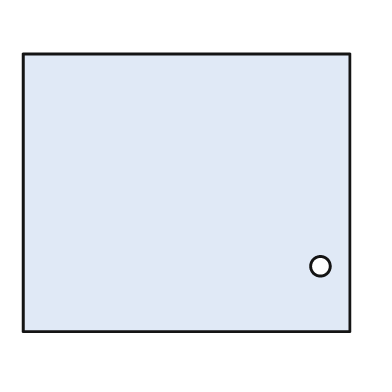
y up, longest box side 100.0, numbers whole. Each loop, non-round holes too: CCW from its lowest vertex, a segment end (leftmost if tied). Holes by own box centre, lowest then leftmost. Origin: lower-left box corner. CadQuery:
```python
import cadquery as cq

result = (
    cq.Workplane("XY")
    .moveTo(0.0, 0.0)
    .lineTo(100.0, 0.0)
    .lineTo(100.0, 85.0)
    .lineTo(0.0, 85.0)
    .close()
    .moveTo(91.0, 20.0)
    .circle(3.0)
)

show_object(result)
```